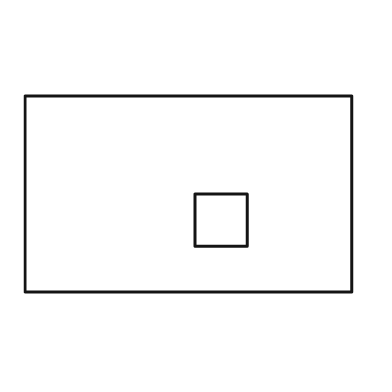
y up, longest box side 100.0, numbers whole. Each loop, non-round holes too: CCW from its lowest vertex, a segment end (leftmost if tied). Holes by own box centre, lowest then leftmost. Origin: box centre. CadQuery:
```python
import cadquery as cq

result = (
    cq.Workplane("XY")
    .moveTo(-50.0, -30.0)
    .lineTo(50.0, -30.0)
    .lineTo(50.0, 30.0)
    .lineTo(-50.0, 30.0)
    .close()
    .moveTo(2.0, -16.0)
    .lineTo(18.0, -16.0)
    .lineTo(18.0, 0.0)
    .lineTo(2.0, 0.0)
    .close()
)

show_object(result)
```